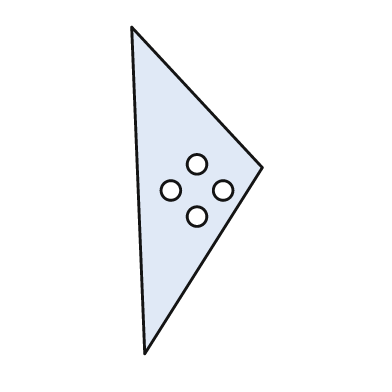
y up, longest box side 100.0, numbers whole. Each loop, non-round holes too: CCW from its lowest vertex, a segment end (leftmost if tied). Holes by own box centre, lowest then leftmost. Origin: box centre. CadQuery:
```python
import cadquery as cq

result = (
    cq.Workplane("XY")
    .moveTo(-16.0, -50.0)
    .lineTo(20.0, 7.0)
    .lineTo(-20.0, 50.0)
    .close()
    .moveTo(0.0, -8.0)
    .circle(3.0)
    .moveTo(-8.0, 0.0)
    .circle(3.0)
    .moveTo(8.0, 0.0)
    .circle(3.0)
    .moveTo(0.0, 8.0)
    .circle(3.0)
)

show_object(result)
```